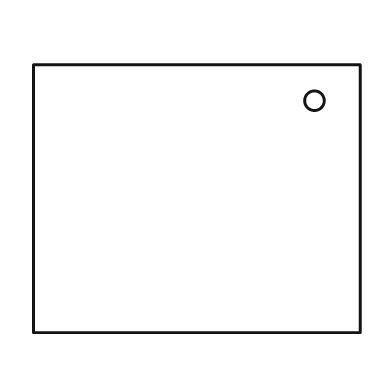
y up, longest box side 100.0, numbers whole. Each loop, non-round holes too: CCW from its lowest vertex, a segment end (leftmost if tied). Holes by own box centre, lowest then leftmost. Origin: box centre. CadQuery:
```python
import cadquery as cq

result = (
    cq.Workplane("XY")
    .moveTo(-50.0, -41.0)
    .lineTo(50.0, -41.0)
    .lineTo(50.0, 41.0)
    .lineTo(-50.0, 41.0)
    .close()
    .moveTo(36.0, 30.0)
    .circle(3.0)
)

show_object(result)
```